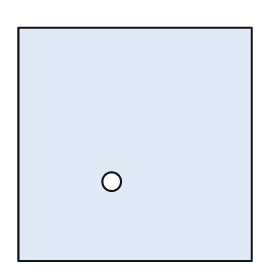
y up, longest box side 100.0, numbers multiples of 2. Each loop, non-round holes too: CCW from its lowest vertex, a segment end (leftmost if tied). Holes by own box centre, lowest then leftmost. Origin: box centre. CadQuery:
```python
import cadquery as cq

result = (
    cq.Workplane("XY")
    .moveTo(-50.0, -50.0)
    .lineTo(50.0, -50.0)
    .lineTo(50.0, 50.0)
    .lineTo(-50.0, 50.0)
    .close()
    .moveTo(-10.0, -16.0)
    .circle(4.0)
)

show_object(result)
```